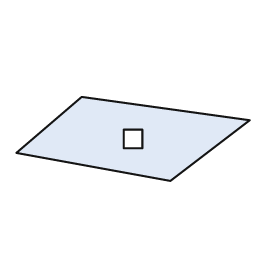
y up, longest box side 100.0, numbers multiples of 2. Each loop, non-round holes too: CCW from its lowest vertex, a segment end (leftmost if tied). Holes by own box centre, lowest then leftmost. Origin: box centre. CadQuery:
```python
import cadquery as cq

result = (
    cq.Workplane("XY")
    .moveTo(16.0, -18.0)
    .lineTo(50.0, 8.0)
    .lineTo(-22.0, 18.0)
    .lineTo(-50.0, -6.0)
    .close()
    .moveTo(-4.0, -4.0)
    .lineTo(4.0, -4.0)
    .lineTo(4.0, 4.0)
    .lineTo(-4.0, 4.0)
    .close()
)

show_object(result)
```